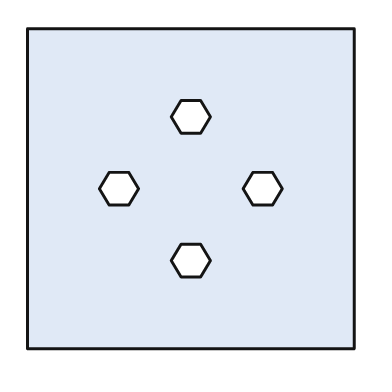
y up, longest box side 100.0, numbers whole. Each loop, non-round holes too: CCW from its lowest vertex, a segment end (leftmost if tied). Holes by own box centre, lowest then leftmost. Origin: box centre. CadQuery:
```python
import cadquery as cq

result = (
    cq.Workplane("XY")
    .moveTo(-50.0, -49.0)
    .lineTo(50.0, -49.0)
    .lineTo(50.0, 49.0)
    .lineTo(-50.0, 49.0)
    .close()
    .moveTo(-3.0, -27.0)
    .lineTo(3.0, -27.0)
    .lineTo(6.0, -22.0)
    .lineTo(3.0, -17.0)
    .lineTo(-3.0, -17.0)
    .lineTo(-6.0, -22.0)
    .close()
    .moveTo(-25.0, -5.0)
    .lineTo(-19.0, -5.0)
    .lineTo(-16.0, 0.0)
    .lineTo(-19.0, 5.0)
    .lineTo(-25.0, 5.0)
    .lineTo(-28.0, 0.0)
    .close()
    .moveTo(19.0, -5.0)
    .lineTo(25.0, -5.0)
    .lineTo(28.0, 0.0)
    .lineTo(25.0, 5.0)
    .lineTo(19.0, 5.0)
    .lineTo(16.0, 0.0)
    .close()
    .moveTo(-3.0, 17.0)
    .lineTo(3.0, 17.0)
    .lineTo(6.0, 22.0)
    .lineTo(3.0, 27.0)
    .lineTo(-3.0, 27.0)
    .lineTo(-6.0, 22.0)
    .close()
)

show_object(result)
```